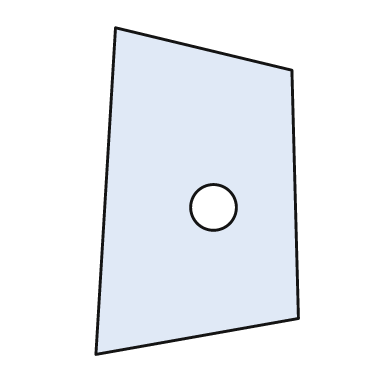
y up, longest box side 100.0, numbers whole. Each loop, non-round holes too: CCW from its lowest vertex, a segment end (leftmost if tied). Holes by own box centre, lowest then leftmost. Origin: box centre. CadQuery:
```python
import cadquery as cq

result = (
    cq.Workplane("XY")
    .moveTo(-31.0, -50.0)
    .lineTo(31.0, -39.0)
    .lineTo(29.0, 37.0)
    .lineTo(-25.0, 50.0)
    .close()
    .moveTo(5.0, -5.0)
    .circle(7.0)
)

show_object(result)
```